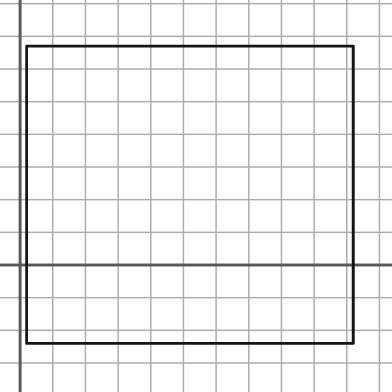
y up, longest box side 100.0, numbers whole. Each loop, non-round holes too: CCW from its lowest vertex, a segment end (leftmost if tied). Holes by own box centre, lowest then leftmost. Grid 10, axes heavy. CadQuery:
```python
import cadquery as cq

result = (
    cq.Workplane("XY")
    .moveTo(2.0, -24.0)
    .lineTo(102.0, -24.0)
    .lineTo(102.0, 67.0)
    .lineTo(2.0, 67.0)
    .close()
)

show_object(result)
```